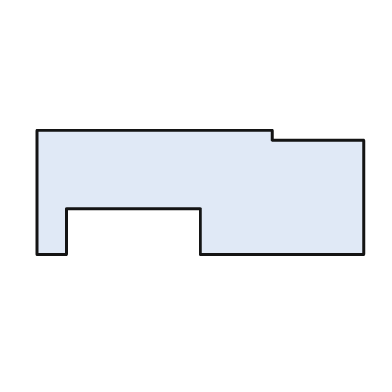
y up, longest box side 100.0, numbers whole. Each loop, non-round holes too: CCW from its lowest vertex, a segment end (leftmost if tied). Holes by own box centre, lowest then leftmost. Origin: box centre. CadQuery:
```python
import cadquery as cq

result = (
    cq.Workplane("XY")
    .moveTo(-50.0, -19.0)
    .lineTo(-41.0, -19.0)
    .lineTo(-41.0, -5.0)
    .lineTo(0.0, -5.0)
    .lineTo(0.0, -19.0)
    .lineTo(50.0, -19.0)
    .lineTo(50.0, 16.0)
    .lineTo(22.0, 16.0)
    .lineTo(22.0, 19.0)
    .lineTo(-50.0, 19.0)
    .close()
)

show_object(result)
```